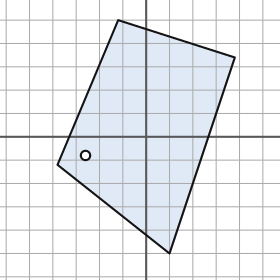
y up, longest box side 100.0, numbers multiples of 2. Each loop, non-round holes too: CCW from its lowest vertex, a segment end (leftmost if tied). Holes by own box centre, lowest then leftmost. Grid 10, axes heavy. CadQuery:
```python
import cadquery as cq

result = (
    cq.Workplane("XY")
    .moveTo(10.0, -50.0)
    .lineTo(38.0, 34.0)
    .lineTo(-12.0, 50.0)
    .lineTo(-38.0, -12.0)
    .close()
    .moveTo(-26.0, -8.0)
    .circle(2.0)
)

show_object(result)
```